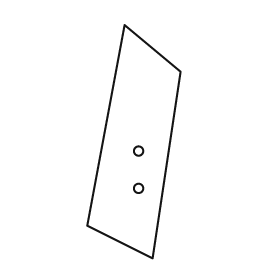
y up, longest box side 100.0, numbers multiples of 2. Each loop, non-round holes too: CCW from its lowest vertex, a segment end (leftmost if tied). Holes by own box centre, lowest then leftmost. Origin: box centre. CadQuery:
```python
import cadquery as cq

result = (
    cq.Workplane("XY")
    .moveTo(8.0, -50.0)
    .lineTo(20.0, 30.0)
    .lineTo(-4.0, 50.0)
    .lineTo(-20.0, -36.0)
    .close()
    .moveTo(2.0, -20.0)
    .circle(2.0)
    .moveTo(2.0, -4.0)
    .circle(2.0)
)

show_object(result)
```